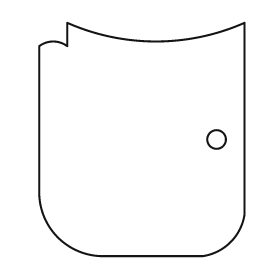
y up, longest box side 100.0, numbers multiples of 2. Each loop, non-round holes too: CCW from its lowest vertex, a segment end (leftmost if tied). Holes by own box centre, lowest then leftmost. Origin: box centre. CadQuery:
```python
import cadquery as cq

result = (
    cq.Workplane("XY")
    .moveTo(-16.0, -50.0)
    .lineTo(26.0, -50.0)
    .threePointArc((38.0, -44.0), (44.0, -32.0))
    .lineTo(44.0, 50.0)
    .threePointArc((6.0, 42.0), (-32.0, 50.0))
    .lineTo(-32.0, 40.0)
    .threePointArc((-38.0, 42.0), (-44.0, 40.0))
    .lineTo(-44.0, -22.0)
    .threePointArc((-36.0, -42.0), (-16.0, -50.0))
    .close()
    .moveTo(32.0, 0.0)
    .circle(4.0)
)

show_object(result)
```